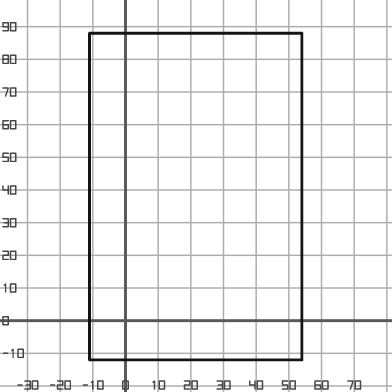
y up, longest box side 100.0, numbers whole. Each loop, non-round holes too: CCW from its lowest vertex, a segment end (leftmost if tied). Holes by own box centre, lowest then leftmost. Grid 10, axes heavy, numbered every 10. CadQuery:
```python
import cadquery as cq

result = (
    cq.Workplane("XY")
    .moveTo(-11.0, -12.0)
    .lineTo(54.0, -12.0)
    .lineTo(54.0, 88.0)
    .lineTo(-11.0, 88.0)
    .close()
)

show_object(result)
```